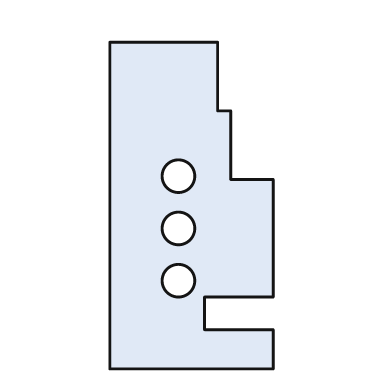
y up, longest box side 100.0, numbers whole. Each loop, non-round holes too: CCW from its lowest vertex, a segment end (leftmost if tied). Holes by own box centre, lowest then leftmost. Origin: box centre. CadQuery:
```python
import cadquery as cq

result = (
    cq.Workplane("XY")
    .moveTo(-25.0, -50.0)
    .lineTo(25.0, -50.0)
    .lineTo(25.0, -38.0)
    .lineTo(4.0, -38.0)
    .lineTo(4.0, -28.0)
    .lineTo(25.0, -28.0)
    .lineTo(25.0, 8.0)
    .lineTo(12.0, 8.0)
    .lineTo(12.0, 29.0)
    .lineTo(8.0, 29.0)
    .lineTo(8.0, 50.0)
    .lineTo(-25.0, 50.0)
    .close()
    .moveTo(-4.0, -23.0)
    .circle(5.0)
    .moveTo(-4.0, -7.0)
    .circle(5.0)
    .moveTo(-4.0, 9.0)
    .circle(5.0)
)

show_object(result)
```